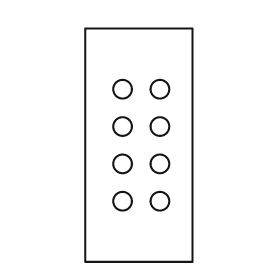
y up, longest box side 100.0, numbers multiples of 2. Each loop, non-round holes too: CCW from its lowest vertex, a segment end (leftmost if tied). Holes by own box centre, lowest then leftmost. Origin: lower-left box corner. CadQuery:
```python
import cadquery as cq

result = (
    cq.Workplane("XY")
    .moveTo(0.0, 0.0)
    .lineTo(46.0, 0.0)
    .lineTo(46.0, 100.0)
    .lineTo(0.0, 100.0)
    .close()
    .moveTo(16.0, 26.0)
    .circle(4.0)
    .moveTo(32.0, 26.0)
    .circle(4.0)
    .moveTo(16.0, 42.0)
    .circle(4.0)
    .moveTo(32.0, 42.0)
    .circle(4.0)
    .moveTo(16.0, 58.0)
    .circle(4.0)
    .moveTo(32.0, 58.0)
    .circle(4.0)
    .moveTo(16.0, 74.0)
    .circle(4.0)
    .moveTo(32.0, 74.0)
    .circle(4.0)
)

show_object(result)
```